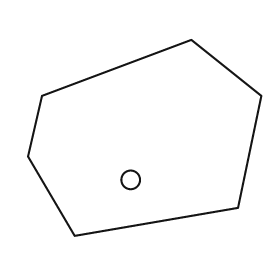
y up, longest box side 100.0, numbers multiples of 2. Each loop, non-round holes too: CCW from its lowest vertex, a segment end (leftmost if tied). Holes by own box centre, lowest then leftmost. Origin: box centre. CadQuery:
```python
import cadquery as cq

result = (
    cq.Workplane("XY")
    .moveTo(-30.0, -42.0)
    .lineTo(40.0, -30.0)
    .lineTo(50.0, 18.0)
    .lineTo(20.0, 42.0)
    .lineTo(-44.0, 18.0)
    .lineTo(-50.0, -8.0)
    .close()
    .moveTo(-6.0, -18.0)
    .circle(4.0)
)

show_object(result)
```